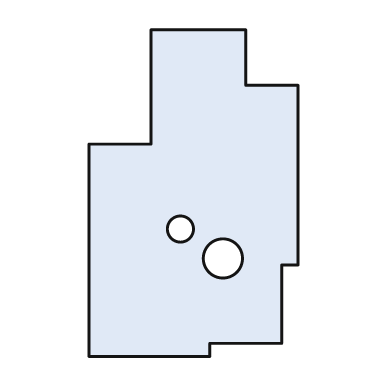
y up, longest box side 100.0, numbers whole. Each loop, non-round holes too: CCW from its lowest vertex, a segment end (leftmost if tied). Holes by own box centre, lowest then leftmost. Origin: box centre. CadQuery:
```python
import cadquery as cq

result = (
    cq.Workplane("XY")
    .moveTo(-32.0, -50.0)
    .lineTo(5.0, -50.0)
    .lineTo(5.0, -46.0)
    .lineTo(27.0, -46.0)
    .lineTo(27.0, -22.0)
    .lineTo(32.0, -22.0)
    .lineTo(32.0, 33.0)
    .lineTo(16.0, 33.0)
    .lineTo(16.0, 50.0)
    .lineTo(-13.0, 50.0)
    .lineTo(-13.0, 15.0)
    .lineTo(-32.0, 15.0)
    .close()
    .moveTo(9.0, -20.0)
    .circle(6.0)
    .moveTo(-4.0, -11.0)
    .circle(4.0)
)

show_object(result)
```